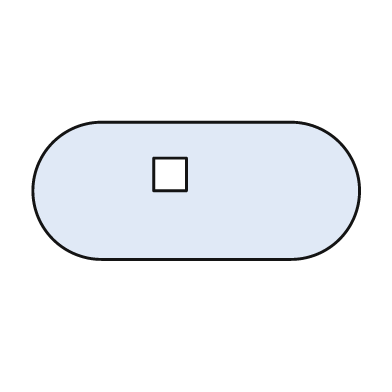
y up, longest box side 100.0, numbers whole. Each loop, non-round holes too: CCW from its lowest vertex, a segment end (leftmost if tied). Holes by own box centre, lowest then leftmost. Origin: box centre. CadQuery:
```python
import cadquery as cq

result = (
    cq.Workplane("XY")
    .moveTo(-29.0, -21.0)
    .lineTo(29.0, -21.0)
    .threePointArc((50.0, 0.0), (29.0, 21.0))
    .lineTo(-29.0, 21.0)
    .threePointArc((-50.0, 0.0), (-29.0, -21.0))
    .close()
    .moveTo(-13.0, 0.0)
    .lineTo(-3.0, 0.0)
    .lineTo(-3.0, 10.0)
    .lineTo(-13.0, 10.0)
    .close()
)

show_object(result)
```